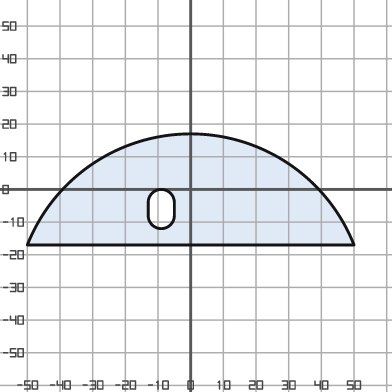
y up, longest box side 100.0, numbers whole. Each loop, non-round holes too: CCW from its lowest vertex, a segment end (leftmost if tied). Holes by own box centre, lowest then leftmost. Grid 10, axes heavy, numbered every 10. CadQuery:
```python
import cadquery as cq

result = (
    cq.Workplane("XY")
    .moveTo(-50.0, -17.0)
    .lineTo(50.0, -17.0)
    .threePointArc((0.0, 17.0), (-50.0, -17.0))
    .close()
    .moveTo(-13.0, -8.0)
    .threePointArc((-9.0, -12.0), (-5.0, -8.0))
    .lineTo(-5.0, -4.0)
    .threePointArc((-9.0, 0.0), (-13.0, -4.0))
    .close()
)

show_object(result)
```